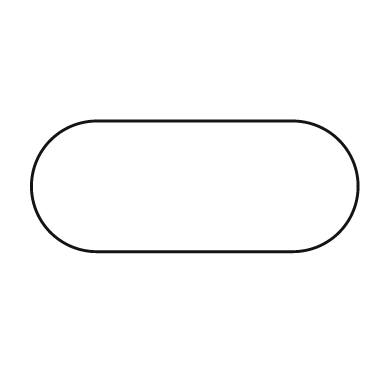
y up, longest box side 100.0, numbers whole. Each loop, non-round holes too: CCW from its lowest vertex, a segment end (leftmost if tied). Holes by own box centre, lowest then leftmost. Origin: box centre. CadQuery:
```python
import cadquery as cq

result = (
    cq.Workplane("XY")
    .moveTo(-30.0, -20.0)
    .lineTo(30.0, -20.0)
    .threePointArc((50.0, 0.0), (30.0, 20.0))
    .lineTo(-30.0, 20.0)
    .threePointArc((-50.0, 0.0), (-30.0, -20.0))
    .close()
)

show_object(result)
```